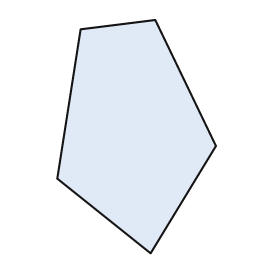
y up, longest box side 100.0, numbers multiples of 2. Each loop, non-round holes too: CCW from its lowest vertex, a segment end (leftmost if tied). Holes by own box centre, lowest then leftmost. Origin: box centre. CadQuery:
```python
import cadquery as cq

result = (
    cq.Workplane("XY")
    .moveTo(6.0, -50.0)
    .lineTo(34.0, -4.0)
    .lineTo(8.0, 50.0)
    .lineTo(-24.0, 46.0)
    .lineTo(-34.0, -18.0)
    .close()
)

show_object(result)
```